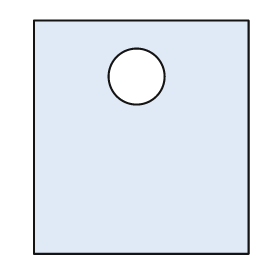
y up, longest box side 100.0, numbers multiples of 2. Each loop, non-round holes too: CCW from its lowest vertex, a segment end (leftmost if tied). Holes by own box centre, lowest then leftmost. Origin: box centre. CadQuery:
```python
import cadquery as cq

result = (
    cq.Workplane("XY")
    .moveTo(-46.0, -50.0)
    .lineTo(46.0, -50.0)
    .lineTo(46.0, 50.0)
    .lineTo(-46.0, 50.0)
    .close()
    .moveTo(-2.0, 26.0)
    .circle(12.0)
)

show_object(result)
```